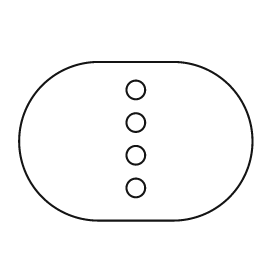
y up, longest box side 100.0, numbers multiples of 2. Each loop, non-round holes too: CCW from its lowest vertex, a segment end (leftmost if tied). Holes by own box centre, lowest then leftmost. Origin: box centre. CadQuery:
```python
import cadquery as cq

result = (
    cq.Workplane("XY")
    .moveTo(-16.0, -34.0)
    .lineTo(16.0, -34.0)
    .threePointArc((50.0, 0.0), (16.0, 34.0))
    .lineTo(-16.0, 34.0)
    .threePointArc((-50.0, 0.0), (-16.0, -34.0))
    .close()
    .moveTo(0.0, -20.0)
    .circle(4.0)
    .moveTo(0.0, -6.0)
    .circle(4.0)
    .moveTo(0.0, 8.0)
    .circle(4.0)
    .moveTo(0.0, 22.0)
    .circle(4.0)
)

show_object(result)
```